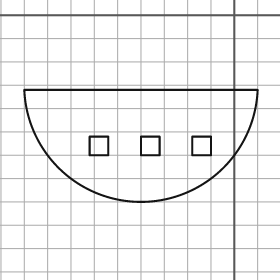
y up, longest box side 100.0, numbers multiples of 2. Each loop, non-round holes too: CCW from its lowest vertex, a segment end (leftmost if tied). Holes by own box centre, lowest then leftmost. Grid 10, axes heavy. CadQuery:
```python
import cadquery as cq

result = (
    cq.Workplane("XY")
    .moveTo(-90.0, -32.0)
    .threePointArc((-40.0, -80.0), (10.0, -32.0))
    .close()
    .moveTo(-62.0, -60.0)
    .lineTo(-54.0, -60.0)
    .lineTo(-54.0, -52.0)
    .lineTo(-62.0, -52.0)
    .close()
    .moveTo(-40.0, -60.0)
    .lineTo(-32.0, -60.0)
    .lineTo(-32.0, -52.0)
    .lineTo(-40.0, -52.0)
    .close()
    .moveTo(-18.0, -60.0)
    .lineTo(-10.0, -60.0)
    .lineTo(-10.0, -52.0)
    .lineTo(-18.0, -52.0)
    .close()
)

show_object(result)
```